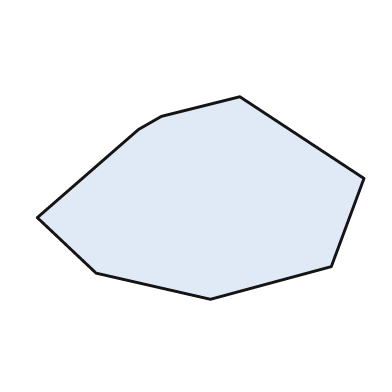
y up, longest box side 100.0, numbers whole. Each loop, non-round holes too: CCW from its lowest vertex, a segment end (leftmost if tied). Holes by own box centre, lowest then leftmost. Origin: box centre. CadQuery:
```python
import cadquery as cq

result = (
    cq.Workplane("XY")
    .moveTo(3.0, -31.0)
    .lineTo(40.0, -21.0)
    .lineTo(50.0, 6.0)
    .lineTo(12.0, 31.0)
    .lineTo(-12.0, 25.0)
    .lineTo(-19.0, 21.0)
    .lineTo(-50.0, -6.0)
    .lineTo(-32.0, -23.0)
    .close()
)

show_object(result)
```